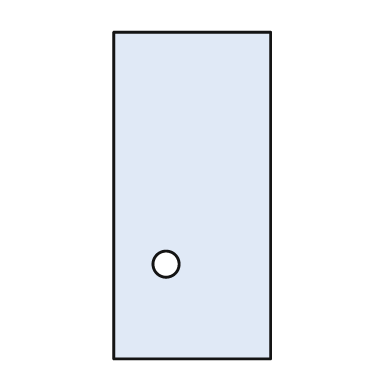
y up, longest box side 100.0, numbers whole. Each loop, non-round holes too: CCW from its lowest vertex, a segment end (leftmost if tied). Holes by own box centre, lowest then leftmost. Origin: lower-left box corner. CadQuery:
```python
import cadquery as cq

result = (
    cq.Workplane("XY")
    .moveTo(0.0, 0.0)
    .lineTo(48.0, 0.0)
    .lineTo(48.0, 100.0)
    .lineTo(0.0, 100.0)
    .close()
    .moveTo(16.0, 29.0)
    .circle(4.0)
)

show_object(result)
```